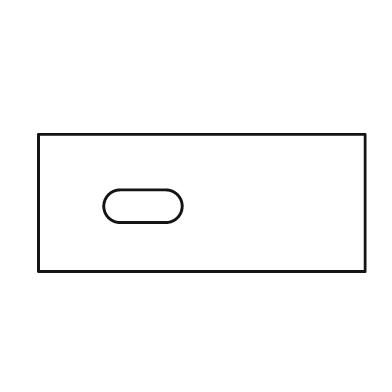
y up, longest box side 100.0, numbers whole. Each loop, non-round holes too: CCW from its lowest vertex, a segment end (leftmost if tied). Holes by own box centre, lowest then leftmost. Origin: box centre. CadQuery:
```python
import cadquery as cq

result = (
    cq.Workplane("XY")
    .moveTo(-50.0, -21.0)
    .lineTo(50.0, -21.0)
    .lineTo(50.0, 21.0)
    .lineTo(-50.0, 21.0)
    .close()
    .moveTo(-25.0, -6.0)
    .lineTo(-11.0, -6.0)
    .threePointArc((-6.0, -1.0), (-11.0, 4.0))
    .lineTo(-25.0, 4.0)
    .threePointArc((-30.0, -1.0), (-25.0, -6.0))
    .close()
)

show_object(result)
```